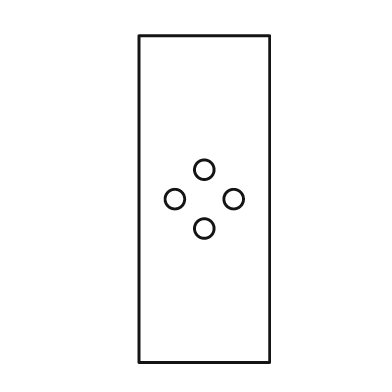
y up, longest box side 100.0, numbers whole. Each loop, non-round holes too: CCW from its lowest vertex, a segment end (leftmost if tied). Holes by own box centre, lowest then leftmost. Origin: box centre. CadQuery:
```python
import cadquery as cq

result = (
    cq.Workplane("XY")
    .moveTo(-20.0, -50.0)
    .lineTo(20.0, -50.0)
    .lineTo(20.0, 50.0)
    .lineTo(-20.0, 50.0)
    .close()
    .moveTo(0.0, -9.0)
    .circle(3.0)
    .moveTo(-9.0, 0.0)
    .circle(3.0)
    .moveTo(9.0, 0.0)
    .circle(3.0)
    .moveTo(0.0, 9.0)
    .circle(3.0)
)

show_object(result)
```